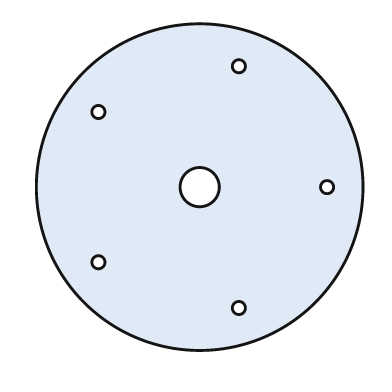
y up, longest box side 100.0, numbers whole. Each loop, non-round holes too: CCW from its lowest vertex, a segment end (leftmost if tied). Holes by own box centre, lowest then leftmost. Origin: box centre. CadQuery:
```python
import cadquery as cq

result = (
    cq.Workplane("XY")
    .moveTo(0.0, 0.0)
    .circle(50.0)
    .moveTo(12.0, -37.0)
    .circle(2.0)
    .moveTo(-31.0, -23.0)
    .circle(2.0)
    .moveTo(0.0, 0.0)
    .circle(6.0)
    .moveTo(39.0, 0.0)
    .circle(2.0)
    .moveTo(-31.0, 23.0)
    .circle(2.0)
    .moveTo(12.0, 37.0)
    .circle(2.0)
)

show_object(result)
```